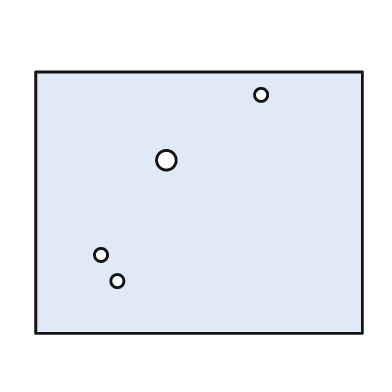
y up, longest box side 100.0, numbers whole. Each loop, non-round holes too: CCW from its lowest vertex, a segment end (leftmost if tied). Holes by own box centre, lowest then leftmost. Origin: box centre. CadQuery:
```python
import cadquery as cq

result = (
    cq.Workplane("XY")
    .moveTo(-50.0, -40.0)
    .lineTo(50.0, -40.0)
    .lineTo(50.0, 40.0)
    .lineTo(-50.0, 40.0)
    .close()
    .moveTo(-25.0, -24.0)
    .circle(2.0)
    .moveTo(-30.0, -16.0)
    .circle(2.0)
    .moveTo(-10.0, 13.0)
    .circle(3.0)
    .moveTo(19.0, 33.0)
    .circle(2.0)
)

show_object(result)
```